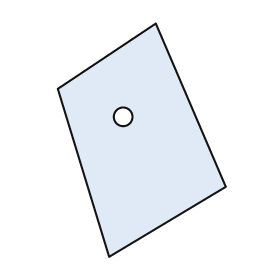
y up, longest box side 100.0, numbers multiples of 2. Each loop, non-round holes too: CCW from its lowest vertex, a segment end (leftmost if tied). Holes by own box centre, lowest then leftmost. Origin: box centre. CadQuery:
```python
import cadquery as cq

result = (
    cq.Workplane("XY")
    .moveTo(-14.0, -50.0)
    .lineTo(36.0, -20.0)
    .lineTo(6.0, 50.0)
    .lineTo(-36.0, 22.0)
    .close()
    .moveTo(-8.0, 10.0)
    .circle(4.0)
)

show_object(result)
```